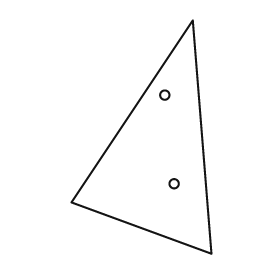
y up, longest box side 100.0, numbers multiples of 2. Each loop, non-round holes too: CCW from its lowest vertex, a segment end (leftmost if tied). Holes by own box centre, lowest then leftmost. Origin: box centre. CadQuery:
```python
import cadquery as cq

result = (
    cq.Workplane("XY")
    .moveTo(30.0, -50.0)
    .lineTo(22.0, 50.0)
    .lineTo(-30.0, -28.0)
    .close()
    .moveTo(14.0, -20.0)
    .circle(2.0)
    .moveTo(10.0, 18.0)
    .circle(2.0)
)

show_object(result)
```